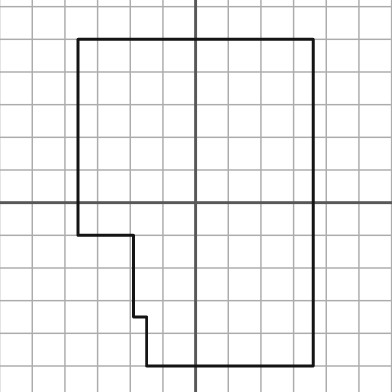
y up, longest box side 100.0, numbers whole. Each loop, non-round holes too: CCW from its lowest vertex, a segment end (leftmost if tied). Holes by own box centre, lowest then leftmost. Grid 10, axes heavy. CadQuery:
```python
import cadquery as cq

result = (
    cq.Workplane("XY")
    .moveTo(-15.0, -50.0)
    .lineTo(36.0, -50.0)
    .lineTo(36.0, 50.0)
    .lineTo(-36.0, 50.0)
    .lineTo(-36.0, -10.0)
    .lineTo(-19.0, -10.0)
    .lineTo(-19.0, -35.0)
    .lineTo(-15.0, -35.0)
    .close()
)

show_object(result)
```